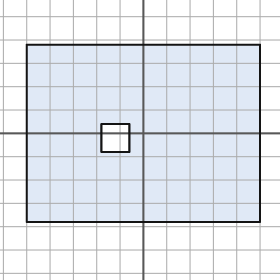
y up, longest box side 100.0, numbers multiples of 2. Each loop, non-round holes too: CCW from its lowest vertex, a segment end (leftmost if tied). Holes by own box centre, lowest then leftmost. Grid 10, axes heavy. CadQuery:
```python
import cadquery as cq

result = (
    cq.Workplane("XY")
    .moveTo(-50.0, -38.0)
    .lineTo(50.0, -38.0)
    .lineTo(50.0, 38.0)
    .lineTo(-50.0, 38.0)
    .close()
    .moveTo(-18.0, -8.0)
    .lineTo(-6.0, -8.0)
    .lineTo(-6.0, 4.0)
    .lineTo(-18.0, 4.0)
    .close()
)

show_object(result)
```